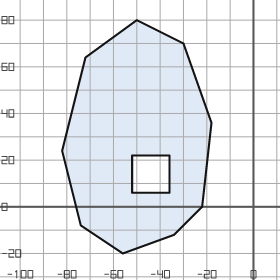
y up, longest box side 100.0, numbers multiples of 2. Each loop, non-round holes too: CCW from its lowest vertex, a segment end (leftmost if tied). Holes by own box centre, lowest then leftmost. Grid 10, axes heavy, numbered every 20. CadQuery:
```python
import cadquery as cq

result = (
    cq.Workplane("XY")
    .moveTo(-56.0, -20.0)
    .lineTo(-34.0, -12.0)
    .lineTo(-22.0, 0.0)
    .lineTo(-18.0, 36.0)
    .lineTo(-30.0, 70.0)
    .lineTo(-50.0, 80.0)
    .lineTo(-72.0, 64.0)
    .lineTo(-82.0, 24.0)
    .lineTo(-74.0, -8.0)
    .close()
    .moveTo(-52.0, 6.0)
    .lineTo(-36.0, 6.0)
    .lineTo(-36.0, 22.0)
    .lineTo(-52.0, 22.0)
    .close()
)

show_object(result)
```